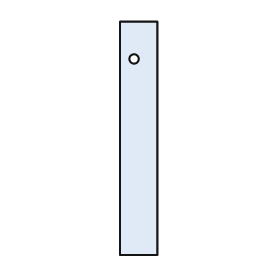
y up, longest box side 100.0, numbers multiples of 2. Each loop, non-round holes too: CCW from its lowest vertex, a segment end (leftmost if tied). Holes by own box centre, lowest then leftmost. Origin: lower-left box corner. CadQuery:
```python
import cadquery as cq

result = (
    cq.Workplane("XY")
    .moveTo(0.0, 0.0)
    .lineTo(16.0, 0.0)
    .lineTo(16.0, 100.0)
    .lineTo(0.0, 100.0)
    .close()
    .moveTo(6.0, 84.0)
    .circle(2.0)
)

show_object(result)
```